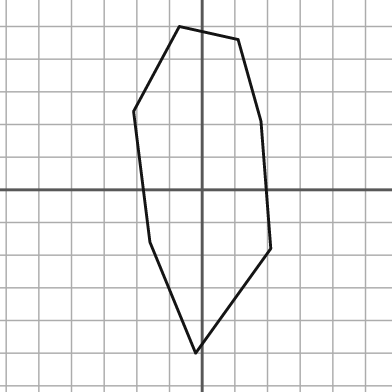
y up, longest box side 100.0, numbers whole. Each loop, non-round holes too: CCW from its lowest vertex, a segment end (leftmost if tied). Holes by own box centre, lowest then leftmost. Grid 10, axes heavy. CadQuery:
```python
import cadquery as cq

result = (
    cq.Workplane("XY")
    .moveTo(-2.0, -50.0)
    .lineTo(21.0, -18.0)
    .lineTo(18.0, 21.0)
    .lineTo(11.0, 46.0)
    .lineTo(-7.0, 50.0)
    .lineTo(-21.0, 24.0)
    .lineTo(-16.0, -16.0)
    .close()
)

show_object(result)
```